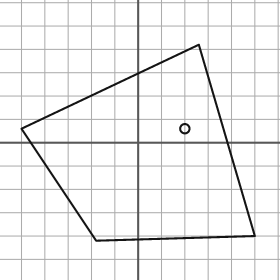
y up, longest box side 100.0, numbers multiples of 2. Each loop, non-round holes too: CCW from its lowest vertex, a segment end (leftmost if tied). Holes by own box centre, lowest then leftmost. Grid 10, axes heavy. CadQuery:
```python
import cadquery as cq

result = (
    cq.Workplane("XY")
    .moveTo(-18.0, -42.0)
    .lineTo(50.0, -40.0)
    .lineTo(26.0, 42.0)
    .lineTo(-50.0, 6.0)
    .close()
    .moveTo(20.0, 6.0)
    .circle(2.0)
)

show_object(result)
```